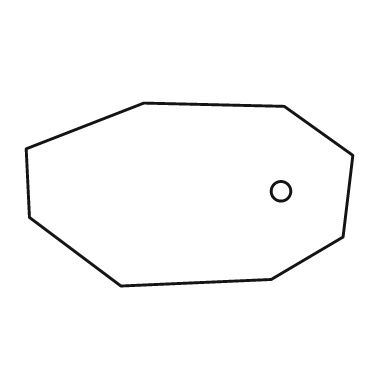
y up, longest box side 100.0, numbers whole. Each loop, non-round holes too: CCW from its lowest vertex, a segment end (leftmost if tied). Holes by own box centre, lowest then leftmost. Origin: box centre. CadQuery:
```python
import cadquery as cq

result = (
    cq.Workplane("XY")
    .moveTo(-21.0, -28.0)
    .lineTo(25.0, -26.0)
    .lineTo(47.0, -13.0)
    .lineTo(50.0, 12.0)
    .lineTo(29.0, 27.0)
    .lineTo(-14.0, 28.0)
    .lineTo(-50.0, 14.0)
    .lineTo(-49.0, -7.0)
    .close()
    .moveTo(28.0, 1.0)
    .circle(3.0)
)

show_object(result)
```